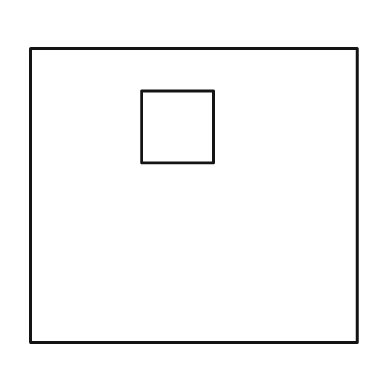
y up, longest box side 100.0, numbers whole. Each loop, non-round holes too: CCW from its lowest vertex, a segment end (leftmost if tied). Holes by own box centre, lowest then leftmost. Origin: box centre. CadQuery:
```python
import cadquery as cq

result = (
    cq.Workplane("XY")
    .moveTo(-50.0, -45.0)
    .lineTo(50.0, -45.0)
    .lineTo(50.0, 45.0)
    .lineTo(-50.0, 45.0)
    .close()
    .moveTo(-16.0, 10.0)
    .lineTo(6.0, 10.0)
    .lineTo(6.0, 32.0)
    .lineTo(-16.0, 32.0)
    .close()
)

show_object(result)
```